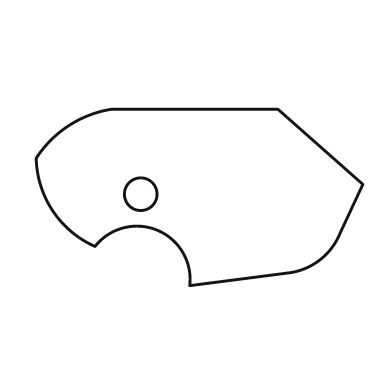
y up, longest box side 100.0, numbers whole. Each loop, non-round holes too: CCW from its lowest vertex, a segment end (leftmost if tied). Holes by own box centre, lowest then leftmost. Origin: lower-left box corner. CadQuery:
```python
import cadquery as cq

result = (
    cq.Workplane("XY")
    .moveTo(47.0, 0.0)
    .lineTo(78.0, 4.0)
    .threePointArc((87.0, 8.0), (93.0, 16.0))
    .lineTo(100.0, 31.0)
    .lineTo(74.0, 54.0)
    .lineTo(23.0, 54.0)
    .threePointArc((10.0, 49.0), (0.0, 39.0))
    .threePointArc((5.0, 23.0), (18.0, 12.0))
    .threePointArc((37.0, 17.0), (47.0, 0.0))
    .close()
    .moveTo(32.0, 28.0)
    .circle(5.0)
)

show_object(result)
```